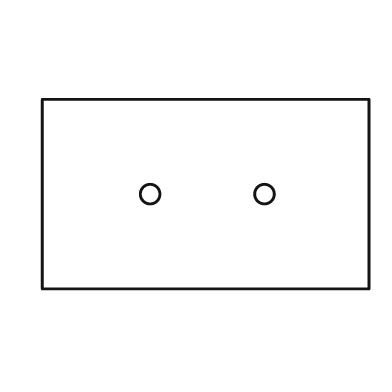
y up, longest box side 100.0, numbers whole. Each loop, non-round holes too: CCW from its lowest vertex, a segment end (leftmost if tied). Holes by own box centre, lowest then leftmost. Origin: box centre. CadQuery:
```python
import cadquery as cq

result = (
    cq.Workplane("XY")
    .moveTo(-50.0, -29.0)
    .lineTo(50.0, -29.0)
    .lineTo(50.0, 29.0)
    .lineTo(-50.0, 29.0)
    .close()
    .moveTo(-17.0, 0.0)
    .circle(3.0)
    .moveTo(18.0, 0.0)
    .circle(3.0)
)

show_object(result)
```